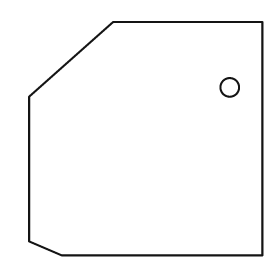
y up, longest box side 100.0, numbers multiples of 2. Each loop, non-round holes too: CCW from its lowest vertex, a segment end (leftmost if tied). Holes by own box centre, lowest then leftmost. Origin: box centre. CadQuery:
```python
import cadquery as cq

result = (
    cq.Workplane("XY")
    .moveTo(-36.0, -50.0)
    .lineTo(50.0, -50.0)
    .lineTo(50.0, 50.0)
    .lineTo(-14.0, 50.0)
    .lineTo(-50.0, 18.0)
    .lineTo(-50.0, -44.0)
    .close()
    .moveTo(36.0, 22.0)
    .circle(4.0)
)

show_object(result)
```